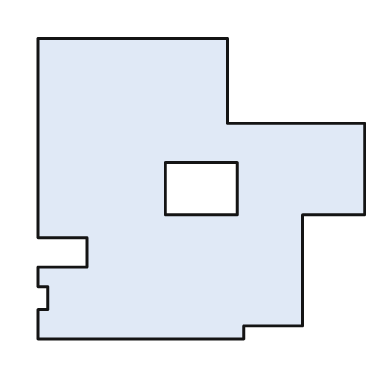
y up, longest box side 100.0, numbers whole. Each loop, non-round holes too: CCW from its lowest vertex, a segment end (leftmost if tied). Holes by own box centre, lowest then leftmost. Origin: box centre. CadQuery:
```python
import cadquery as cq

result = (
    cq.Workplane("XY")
    .moveTo(-50.0, -46.0)
    .lineTo(13.0, -46.0)
    .lineTo(13.0, -42.0)
    .lineTo(31.0, -42.0)
    .lineTo(31.0, -8.0)
    .lineTo(50.0, -8.0)
    .lineTo(50.0, 20.0)
    .lineTo(8.0, 20.0)
    .lineTo(8.0, 46.0)
    .lineTo(-50.0, 46.0)
    .lineTo(-50.0, -15.0)
    .lineTo(-35.0, -15.0)
    .lineTo(-35.0, -24.0)
    .lineTo(-50.0, -24.0)
    .lineTo(-50.0, -30.0)
    .lineTo(-47.0, -30.0)
    .lineTo(-47.0, -37.0)
    .lineTo(-50.0, -37.0)
    .close()
    .moveTo(-11.0, -8.0)
    .lineTo(11.0, -8.0)
    .lineTo(11.0, 8.0)
    .lineTo(-11.0, 8.0)
    .close()
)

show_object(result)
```